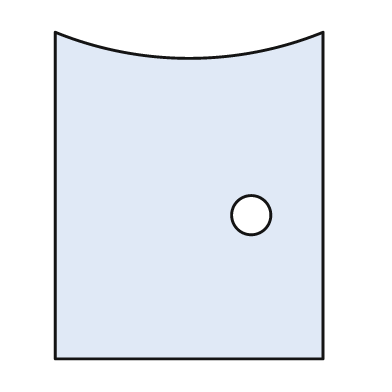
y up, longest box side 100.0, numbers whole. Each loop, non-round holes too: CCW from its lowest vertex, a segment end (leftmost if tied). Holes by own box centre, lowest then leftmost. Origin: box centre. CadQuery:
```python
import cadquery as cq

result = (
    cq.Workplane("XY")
    .moveTo(-41.0, -50.0)
    .lineTo(41.0, -50.0)
    .lineTo(41.0, 50.0)
    .threePointArc((0.0, 42.0), (-41.0, 50.0))
    .close()
    .moveTo(19.0, -6.0)
    .circle(6.0)
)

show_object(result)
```